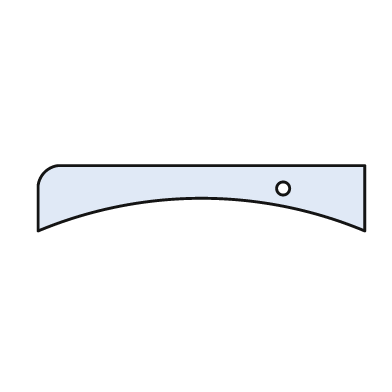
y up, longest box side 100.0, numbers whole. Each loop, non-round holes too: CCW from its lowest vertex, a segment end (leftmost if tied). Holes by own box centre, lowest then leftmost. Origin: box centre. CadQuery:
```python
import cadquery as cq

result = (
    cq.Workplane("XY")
    .moveTo(-50.0, -10.0)
    .threePointArc((0.0, 0.0), (50.0, -10.0))
    .lineTo(50.0, 10.0)
    .lineTo(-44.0, 10.0)
    .threePointArc((-48.0, 8.0), (-50.0, 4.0))
    .close()
    .moveTo(25.0, 3.0)
    .circle(2.0)
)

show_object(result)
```